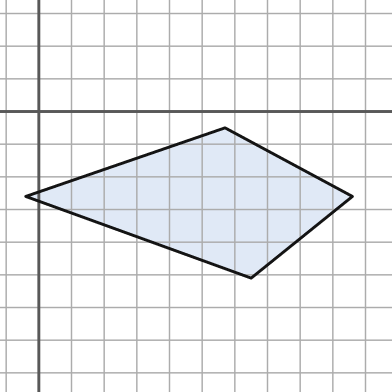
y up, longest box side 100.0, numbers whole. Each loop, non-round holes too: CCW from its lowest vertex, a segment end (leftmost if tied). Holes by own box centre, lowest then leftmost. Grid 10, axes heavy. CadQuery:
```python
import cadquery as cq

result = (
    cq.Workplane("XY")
    .moveTo(65.0, -51.0)
    .lineTo(96.0, -26.0)
    .lineTo(57.0, -5.0)
    .lineTo(-4.0, -26.0)
    .close()
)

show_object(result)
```